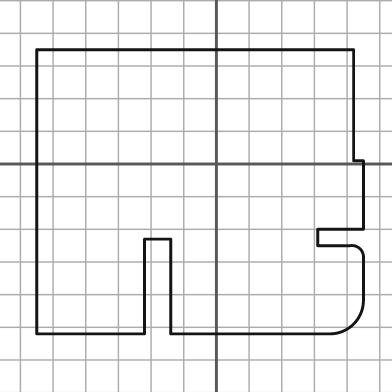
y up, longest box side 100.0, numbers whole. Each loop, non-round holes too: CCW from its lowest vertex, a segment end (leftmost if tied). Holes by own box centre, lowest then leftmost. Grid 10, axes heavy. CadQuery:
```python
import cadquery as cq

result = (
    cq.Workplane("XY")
    .moveTo(-55.0, -52.0)
    .lineTo(-22.0, -52.0)
    .lineTo(-22.0, -23.0)
    .lineTo(-14.0, -23.0)
    .lineTo(-14.0, -52.0)
    .lineTo(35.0, -52.0)
    .threePointArc((42.0, -49.0), (45.0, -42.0))
    .lineTo(45.0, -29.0)
    .threePointArc((44.0, -26.0), (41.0, -25.0))
    .lineTo(31.0, -25.0)
    .lineTo(31.0, -20.0)
    .lineTo(45.0, -20.0)
    .lineTo(45.0, 1.0)
    .lineTo(42.0, 1.0)
    .lineTo(42.0, 35.0)
    .lineTo(-55.0, 35.0)
    .close()
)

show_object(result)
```